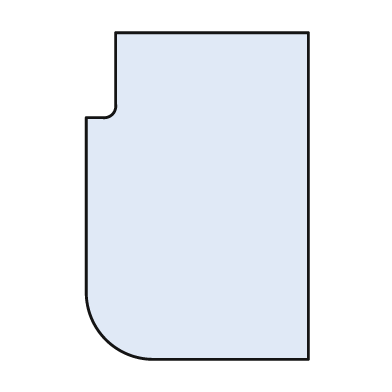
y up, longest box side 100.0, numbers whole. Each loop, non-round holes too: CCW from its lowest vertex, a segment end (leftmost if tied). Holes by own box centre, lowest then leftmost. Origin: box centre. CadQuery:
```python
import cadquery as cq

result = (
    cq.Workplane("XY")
    .moveTo(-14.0, -50.0)
    .lineTo(34.0, -50.0)
    .lineTo(34.0, 50.0)
    .lineTo(-25.0, 50.0)
    .lineTo(-25.0, 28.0)
    .threePointArc((-26.0, 25.0), (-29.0, 24.0))
    .lineTo(-34.0, 24.0)
    .lineTo(-34.0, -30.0)
    .threePointArc((-28.0, -44.0), (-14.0, -50.0))
    .close()
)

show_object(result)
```